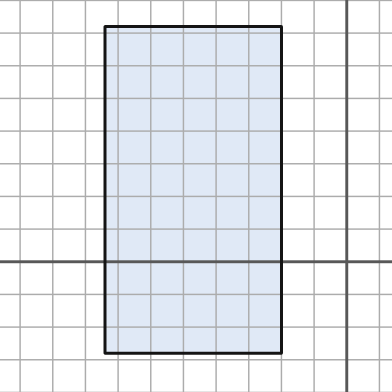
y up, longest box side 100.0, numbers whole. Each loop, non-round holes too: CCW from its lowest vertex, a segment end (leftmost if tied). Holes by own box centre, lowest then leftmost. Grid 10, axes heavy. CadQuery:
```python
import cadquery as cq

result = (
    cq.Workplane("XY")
    .moveTo(-74.0, -28.0)
    .lineTo(-20.0, -28.0)
    .lineTo(-20.0, 72.0)
    .lineTo(-74.0, 72.0)
    .close()
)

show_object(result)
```